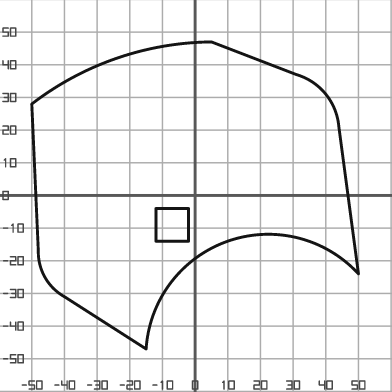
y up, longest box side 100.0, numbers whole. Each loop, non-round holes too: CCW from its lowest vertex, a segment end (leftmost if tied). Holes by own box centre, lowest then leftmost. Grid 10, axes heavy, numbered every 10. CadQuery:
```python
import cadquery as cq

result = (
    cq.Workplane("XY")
    .moveTo(-15.0, -47.0)
    .threePointArc((10.0, -14.0), (50.0, -24.0))
    .lineTo(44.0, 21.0)
    .threePointArc((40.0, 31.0), (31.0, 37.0))
    .lineTo(5.0, 47.0)
    .threePointArc((-24.0, 42.0), (-50.0, 28.0))
    .lineTo(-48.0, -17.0)
    .threePointArc((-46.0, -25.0), (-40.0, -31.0))
    .close()
    .moveTo(-12.0, -14.0)
    .lineTo(-2.0, -14.0)
    .lineTo(-2.0, -4.0)
    .lineTo(-12.0, -4.0)
    .close()
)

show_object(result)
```